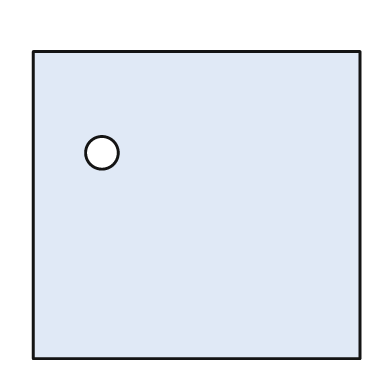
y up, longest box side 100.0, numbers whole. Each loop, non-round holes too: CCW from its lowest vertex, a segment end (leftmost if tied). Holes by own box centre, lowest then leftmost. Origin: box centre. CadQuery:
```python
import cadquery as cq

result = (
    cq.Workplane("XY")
    .moveTo(-50.0, -47.0)
    .lineTo(50.0, -47.0)
    .lineTo(50.0, 47.0)
    .lineTo(-50.0, 47.0)
    .close()
    .moveTo(-29.0, 16.0)
    .circle(5.0)
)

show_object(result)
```